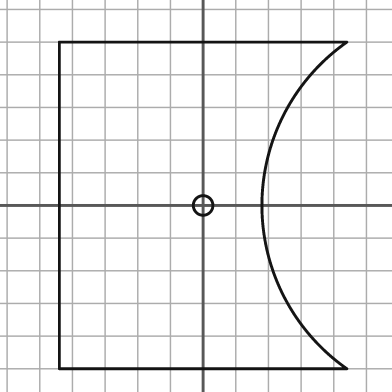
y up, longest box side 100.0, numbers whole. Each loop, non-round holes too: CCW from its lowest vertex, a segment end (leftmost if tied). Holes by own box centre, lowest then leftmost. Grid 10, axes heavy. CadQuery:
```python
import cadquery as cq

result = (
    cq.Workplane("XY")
    .moveTo(-44.0, -50.0)
    .lineTo(44.0, -50.0)
    .threePointArc((18.0, 0.0), (44.0, 50.0))
    .lineTo(-44.0, 50.0)
    .close()
    .moveTo(0.0, 0.0)
    .circle(3.0)
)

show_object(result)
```